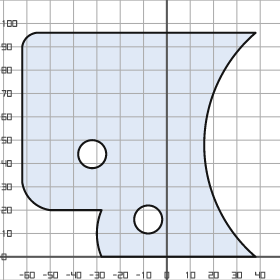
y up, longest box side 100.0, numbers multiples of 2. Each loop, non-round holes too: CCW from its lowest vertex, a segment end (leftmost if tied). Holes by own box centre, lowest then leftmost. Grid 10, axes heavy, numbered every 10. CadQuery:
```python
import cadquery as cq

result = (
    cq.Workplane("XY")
    .moveTo(-28.0, 0.0)
    .lineTo(38.0, 0.0)
    .threePointArc((16.0, 48.0), (38.0, 96.0))
    .lineTo(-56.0, 96.0)
    .threePointArc((-60.0, 94.0), (-62.0, 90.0))
    .lineTo(-62.0, 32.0)
    .threePointArc((-58.0, 24.0), (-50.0, 20.0))
    .lineTo(-28.0, 20.0)
    .threePointArc((-30.0, 10.0), (-28.0, 0.0))
    .close()
    .moveTo(-8.0, 16.0)
    .circle(6.0)
    .moveTo(-32.0, 44.0)
    .circle(6.0)
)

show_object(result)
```